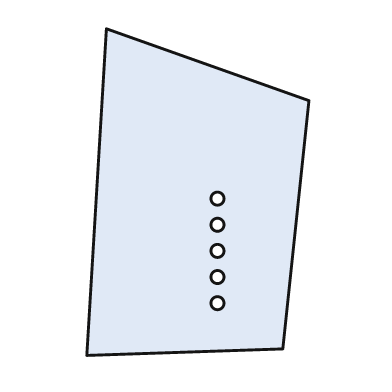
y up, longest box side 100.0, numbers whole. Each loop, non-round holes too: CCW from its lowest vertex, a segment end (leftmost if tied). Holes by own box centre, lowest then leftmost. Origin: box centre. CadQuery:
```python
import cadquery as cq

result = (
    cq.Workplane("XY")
    .moveTo(-34.0, -50.0)
    .lineTo(26.0, -48.0)
    .lineTo(34.0, 28.0)
    .lineTo(-28.0, 50.0)
    .close()
    .moveTo(6.0, -34.0)
    .circle(2.0)
    .moveTo(6.0, -26.0)
    .circle(2.0)
    .moveTo(6.0, -18.0)
    .circle(2.0)
    .moveTo(6.0, -10.0)
    .circle(2.0)
    .moveTo(6.0, -2.0)
    .circle(2.0)
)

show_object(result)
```